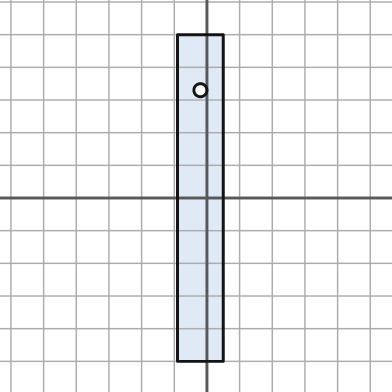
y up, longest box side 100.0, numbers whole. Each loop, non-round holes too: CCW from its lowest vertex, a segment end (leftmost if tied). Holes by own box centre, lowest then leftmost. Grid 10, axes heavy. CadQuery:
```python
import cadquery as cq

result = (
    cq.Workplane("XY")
    .moveTo(-9.0, -50.0)
    .lineTo(5.0, -50.0)
    .lineTo(5.0, 50.0)
    .lineTo(-9.0, 50.0)
    .close()
    .moveTo(-2.0, 33.0)
    .circle(2.0)
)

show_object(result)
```